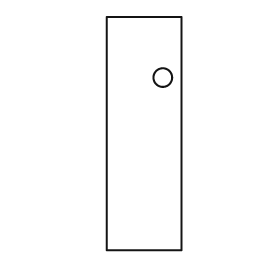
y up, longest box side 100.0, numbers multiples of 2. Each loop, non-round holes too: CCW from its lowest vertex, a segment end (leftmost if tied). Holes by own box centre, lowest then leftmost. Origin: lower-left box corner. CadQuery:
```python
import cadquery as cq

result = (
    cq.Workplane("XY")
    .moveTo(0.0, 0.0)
    .lineTo(32.0, 0.0)
    .lineTo(32.0, 100.0)
    .lineTo(0.0, 100.0)
    .close()
    .moveTo(24.0, 74.0)
    .circle(4.0)
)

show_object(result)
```